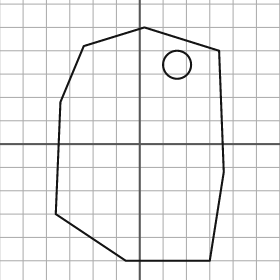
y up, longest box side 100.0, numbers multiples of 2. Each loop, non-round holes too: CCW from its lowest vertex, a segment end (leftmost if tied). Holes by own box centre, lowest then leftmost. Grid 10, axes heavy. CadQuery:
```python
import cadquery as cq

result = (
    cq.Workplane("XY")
    .moveTo(-6.0, -50.0)
    .lineTo(30.0, -50.0)
    .lineTo(36.0, -12.0)
    .lineTo(34.0, 40.0)
    .lineTo(2.0, 50.0)
    .lineTo(-24.0, 42.0)
    .lineTo(-34.0, 18.0)
    .lineTo(-36.0, -30.0)
    .close()
    .moveTo(16.0, 34.0)
    .circle(6.0)
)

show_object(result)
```